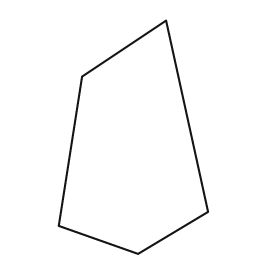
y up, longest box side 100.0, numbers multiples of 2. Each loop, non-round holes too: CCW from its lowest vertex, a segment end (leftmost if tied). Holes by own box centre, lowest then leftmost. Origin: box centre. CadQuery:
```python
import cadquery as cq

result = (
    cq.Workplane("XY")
    .moveTo(2.0, -50.0)
    .lineTo(32.0, -32.0)
    .lineTo(14.0, 50.0)
    .lineTo(-22.0, 26.0)
    .lineTo(-32.0, -38.0)
    .close()
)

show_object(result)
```